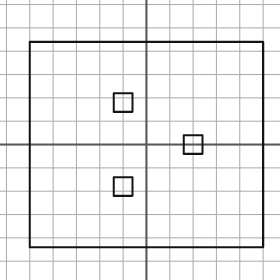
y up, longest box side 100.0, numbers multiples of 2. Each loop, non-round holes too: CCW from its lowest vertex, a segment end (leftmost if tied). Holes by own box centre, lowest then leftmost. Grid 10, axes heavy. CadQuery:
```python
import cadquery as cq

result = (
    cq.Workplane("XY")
    .moveTo(-50.0, -44.0)
    .lineTo(50.0, -44.0)
    .lineTo(50.0, 44.0)
    .lineTo(-50.0, 44.0)
    .close()
    .moveTo(-14.0, -22.0)
    .lineTo(-6.0, -22.0)
    .lineTo(-6.0, -14.0)
    .lineTo(-14.0, -14.0)
    .close()
    .moveTo(16.0, -4.0)
    .lineTo(24.0, -4.0)
    .lineTo(24.0, 4.0)
    .lineTo(16.0, 4.0)
    .close()
    .moveTo(-14.0, 14.0)
    .lineTo(-6.0, 14.0)
    .lineTo(-6.0, 22.0)
    .lineTo(-14.0, 22.0)
    .close()
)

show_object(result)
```